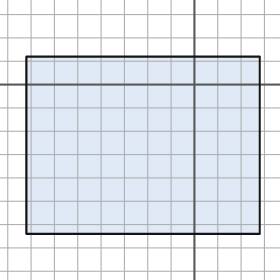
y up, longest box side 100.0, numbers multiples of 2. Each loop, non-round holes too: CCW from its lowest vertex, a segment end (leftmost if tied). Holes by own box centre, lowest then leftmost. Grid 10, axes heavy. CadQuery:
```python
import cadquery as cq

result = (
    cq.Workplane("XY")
    .moveTo(-72.0, -64.0)
    .lineTo(28.0, -64.0)
    .lineTo(28.0, 12.0)
    .lineTo(-72.0, 12.0)
    .close()
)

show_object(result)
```